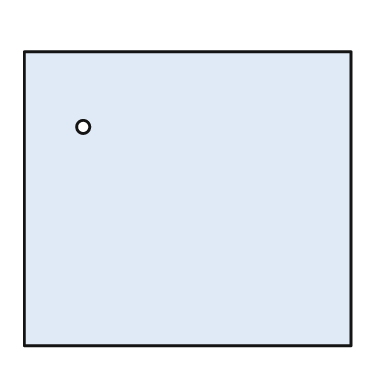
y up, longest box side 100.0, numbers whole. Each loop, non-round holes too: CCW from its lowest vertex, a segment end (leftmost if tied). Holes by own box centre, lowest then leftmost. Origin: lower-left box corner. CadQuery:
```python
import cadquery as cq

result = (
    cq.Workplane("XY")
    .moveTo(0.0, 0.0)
    .lineTo(100.0, 0.0)
    .lineTo(100.0, 90.0)
    .lineTo(0.0, 90.0)
    .close()
    .moveTo(18.0, 67.0)
    .circle(2.0)
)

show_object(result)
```